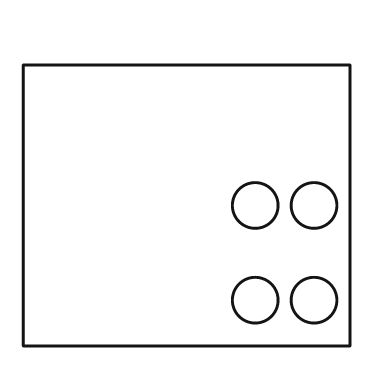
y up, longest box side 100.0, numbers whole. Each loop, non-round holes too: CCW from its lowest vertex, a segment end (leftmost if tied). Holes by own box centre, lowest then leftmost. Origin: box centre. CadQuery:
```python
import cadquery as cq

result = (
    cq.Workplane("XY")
    .moveTo(-50.0, -43.0)
    .lineTo(50.0, -43.0)
    .lineTo(50.0, 43.0)
    .lineTo(-50.0, 43.0)
    .close()
    .moveTo(21.0, -29.0)
    .circle(7.0)
    .moveTo(39.0, -29.0)
    .circle(7.0)
    .moveTo(21.0, 0.0)
    .circle(7.0)
    .moveTo(39.0, 0.0)
    .circle(7.0)
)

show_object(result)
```